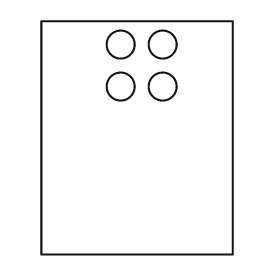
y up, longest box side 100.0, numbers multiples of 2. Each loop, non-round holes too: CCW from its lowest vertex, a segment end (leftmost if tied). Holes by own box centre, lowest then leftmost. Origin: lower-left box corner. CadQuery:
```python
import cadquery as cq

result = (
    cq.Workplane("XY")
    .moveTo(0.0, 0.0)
    .lineTo(82.0, 0.0)
    .lineTo(82.0, 100.0)
    .lineTo(0.0, 100.0)
    .close()
    .moveTo(34.0, 72.0)
    .circle(6.0)
    .moveTo(52.0, 72.0)
    .circle(6.0)
    .moveTo(34.0, 90.0)
    .circle(6.0)
    .moveTo(52.0, 90.0)
    .circle(6.0)
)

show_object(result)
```